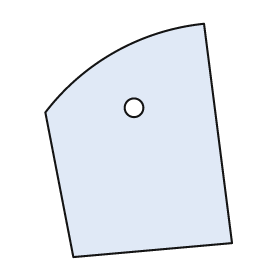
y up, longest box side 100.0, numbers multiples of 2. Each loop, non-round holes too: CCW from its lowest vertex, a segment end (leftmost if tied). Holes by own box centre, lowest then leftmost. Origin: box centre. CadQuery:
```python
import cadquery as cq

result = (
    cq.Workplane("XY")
    .moveTo(-28.0, -50.0)
    .lineTo(40.0, -44.0)
    .lineTo(28.0, 50.0)
    .threePointArc((-10.0, 38.0), (-40.0, 12.0))
    .close()
    .moveTo(-2.0, 14.0)
    .circle(4.0)
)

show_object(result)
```